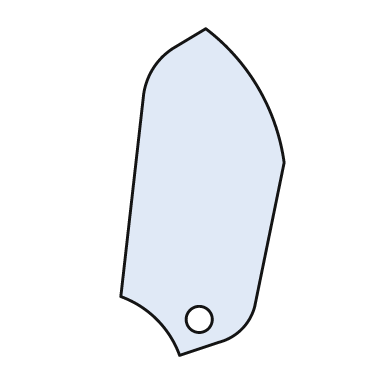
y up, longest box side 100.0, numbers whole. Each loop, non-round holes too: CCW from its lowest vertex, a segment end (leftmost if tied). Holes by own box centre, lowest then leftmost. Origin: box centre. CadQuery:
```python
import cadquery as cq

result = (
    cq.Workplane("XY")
    .moveTo(-7.0, -50.0)
    .lineTo(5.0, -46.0)
    .threePointArc((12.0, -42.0), (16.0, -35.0))
    .lineTo(25.0, 9.0)
    .threePointArc((17.0, 32.0), (1.0, 50.0))
    .lineTo(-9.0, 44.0)
    .threePointArc((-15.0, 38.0), (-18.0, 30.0))
    .lineTo(-25.0, -32.0)
    .threePointArc((-14.0, -39.0), (-7.0, -50.0))
    .close()
    .moveTo(-1.0, -39.0)
    .circle(4.0)
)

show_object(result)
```